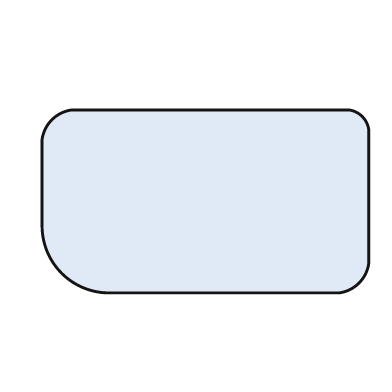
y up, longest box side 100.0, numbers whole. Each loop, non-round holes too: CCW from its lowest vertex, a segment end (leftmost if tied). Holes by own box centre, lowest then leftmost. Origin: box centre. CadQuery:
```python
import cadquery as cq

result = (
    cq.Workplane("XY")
    .moveTo(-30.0, -28.0)
    .lineTo(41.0, -28.0)
    .threePointArc((47.0, -25.0), (50.0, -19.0))
    .lineTo(50.0, 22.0)
    .threePointArc((48.0, 26.0), (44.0, 28.0))
    .lineTo(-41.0, 28.0)
    .threePointArc((-47.0, 25.0), (-50.0, 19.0))
    .lineTo(-50.0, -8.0)
    .threePointArc((-44.0, -22.0), (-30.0, -28.0))
    .close()
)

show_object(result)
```